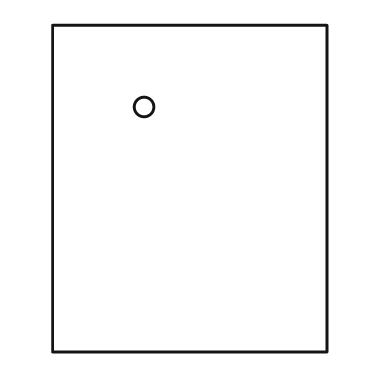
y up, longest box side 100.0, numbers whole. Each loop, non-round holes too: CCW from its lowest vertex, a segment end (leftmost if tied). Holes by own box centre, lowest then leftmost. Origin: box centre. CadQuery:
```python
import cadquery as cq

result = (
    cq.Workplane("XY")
    .moveTo(-42.0, -50.0)
    .lineTo(42.0, -50.0)
    .lineTo(42.0, 50.0)
    .lineTo(-42.0, 50.0)
    .close()
    .moveTo(-14.0, 25.0)
    .circle(3.0)
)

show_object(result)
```